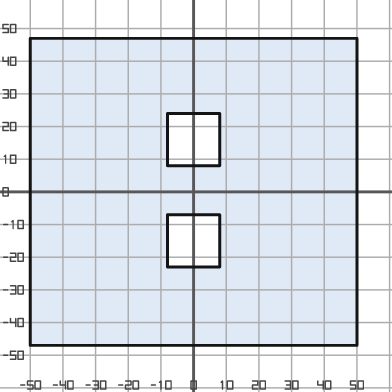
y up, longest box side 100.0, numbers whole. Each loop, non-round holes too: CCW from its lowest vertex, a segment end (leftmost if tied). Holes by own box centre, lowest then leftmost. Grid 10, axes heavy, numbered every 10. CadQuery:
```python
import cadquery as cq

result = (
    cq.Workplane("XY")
    .moveTo(-50.0, -47.0)
    .lineTo(50.0, -47.0)
    .lineTo(50.0, 47.0)
    .lineTo(-50.0, 47.0)
    .close()
    .moveTo(-8.0, -23.0)
    .lineTo(8.0, -23.0)
    .lineTo(8.0, -7.0)
    .lineTo(-8.0, -7.0)
    .close()
    .moveTo(-8.0, 8.0)
    .lineTo(8.0, 8.0)
    .lineTo(8.0, 24.0)
    .lineTo(-8.0, 24.0)
    .close()
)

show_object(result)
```